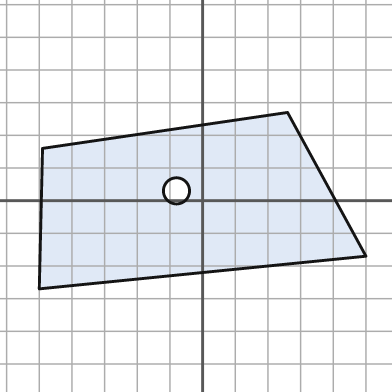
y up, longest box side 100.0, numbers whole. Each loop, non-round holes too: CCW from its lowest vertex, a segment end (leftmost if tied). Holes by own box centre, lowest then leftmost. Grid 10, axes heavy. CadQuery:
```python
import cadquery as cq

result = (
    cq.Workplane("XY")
    .moveTo(-50.0, -27.0)
    .lineTo(50.0, -17.0)
    .lineTo(26.0, 27.0)
    .lineTo(-49.0, 16.0)
    .close()
    .moveTo(-8.0, 3.0)
    .circle(4.0)
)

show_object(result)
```